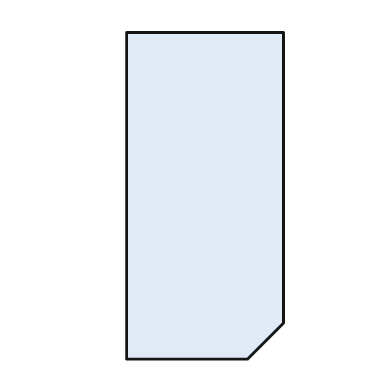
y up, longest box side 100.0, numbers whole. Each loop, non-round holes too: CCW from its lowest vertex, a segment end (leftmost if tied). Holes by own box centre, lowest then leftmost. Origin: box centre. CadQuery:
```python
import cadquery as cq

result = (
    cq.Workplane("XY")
    .moveTo(-24.0, -50.0)
    .lineTo(13.0, -50.0)
    .lineTo(24.0, -39.0)
    .lineTo(24.0, 50.0)
    .lineTo(-24.0, 50.0)
    .close()
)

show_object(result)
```